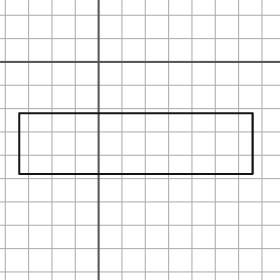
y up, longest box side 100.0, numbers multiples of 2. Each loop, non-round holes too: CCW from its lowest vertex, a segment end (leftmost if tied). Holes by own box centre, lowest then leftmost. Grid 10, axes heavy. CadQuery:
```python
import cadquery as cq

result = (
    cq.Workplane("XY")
    .moveTo(-34.0, -48.0)
    .lineTo(66.0, -48.0)
    .lineTo(66.0, -22.0)
    .lineTo(-34.0, -22.0)
    .close()
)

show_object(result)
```